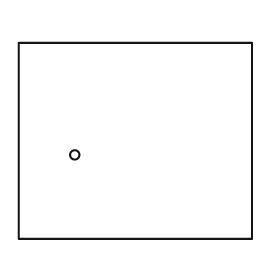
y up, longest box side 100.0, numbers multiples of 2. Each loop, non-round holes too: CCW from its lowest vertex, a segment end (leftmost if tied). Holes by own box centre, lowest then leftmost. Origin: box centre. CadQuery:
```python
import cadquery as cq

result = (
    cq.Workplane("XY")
    .moveTo(-50.0, -42.0)
    .lineTo(50.0, -42.0)
    .lineTo(50.0, 42.0)
    .lineTo(-50.0, 42.0)
    .close()
    .moveTo(-26.0, -6.0)
    .circle(2.0)
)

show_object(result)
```